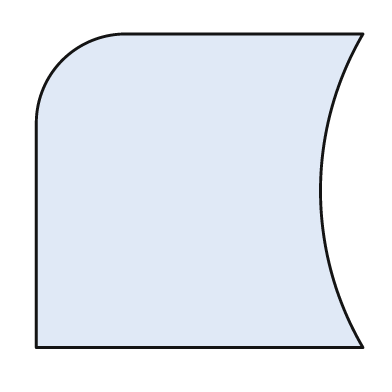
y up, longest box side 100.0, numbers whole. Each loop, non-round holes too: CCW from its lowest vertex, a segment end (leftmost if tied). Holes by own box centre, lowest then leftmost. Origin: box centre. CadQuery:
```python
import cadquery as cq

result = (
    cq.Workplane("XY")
    .moveTo(-50.0, -48.0)
    .lineTo(50.0, -48.0)
    .threePointArc((37.0, 0.0), (50.0, 48.0))
    .lineTo(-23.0, 48.0)
    .threePointArc((-42.0, 40.0), (-50.0, 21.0))
    .close()
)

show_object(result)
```